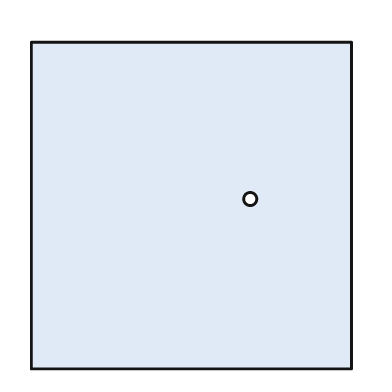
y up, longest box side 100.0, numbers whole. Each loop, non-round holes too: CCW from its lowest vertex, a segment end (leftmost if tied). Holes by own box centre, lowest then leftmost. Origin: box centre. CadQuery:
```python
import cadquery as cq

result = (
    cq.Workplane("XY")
    .moveTo(-49.0, -50.0)
    .lineTo(49.0, -50.0)
    .lineTo(49.0, 50.0)
    .lineTo(-49.0, 50.0)
    .close()
    .moveTo(18.0, 2.0)
    .circle(2.0)
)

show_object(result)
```